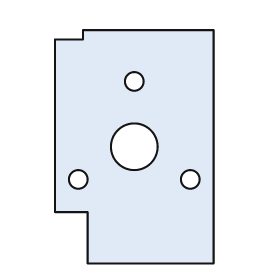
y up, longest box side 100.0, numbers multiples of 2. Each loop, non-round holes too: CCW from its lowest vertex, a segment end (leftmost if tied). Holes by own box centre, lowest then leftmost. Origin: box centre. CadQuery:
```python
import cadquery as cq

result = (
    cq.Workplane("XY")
    .moveTo(-20.0, -50.0)
    .lineTo(34.0, -50.0)
    .lineTo(34.0, 50.0)
    .lineTo(-22.0, 50.0)
    .lineTo(-22.0, 46.0)
    .lineTo(-34.0, 46.0)
    .lineTo(-34.0, -28.0)
    .lineTo(-20.0, -28.0)
    .close()
    .moveTo(-24.0, -14.0)
    .circle(4.0)
    .moveTo(24.0, -14.0)
    .circle(4.0)
    .moveTo(0.0, 0.0)
    .circle(10.0)
    .moveTo(0.0, 28.0)
    .circle(4.0)
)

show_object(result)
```